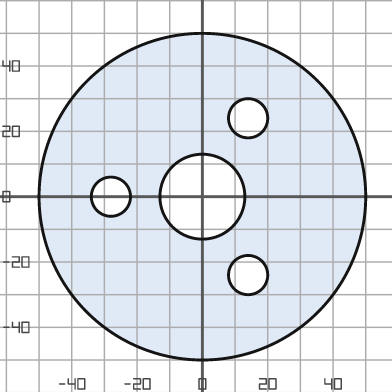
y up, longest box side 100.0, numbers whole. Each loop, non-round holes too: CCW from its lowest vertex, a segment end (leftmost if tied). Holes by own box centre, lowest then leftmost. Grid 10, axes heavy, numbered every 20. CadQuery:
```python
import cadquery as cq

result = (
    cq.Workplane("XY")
    .moveTo(0.0, 0.0)
    .circle(50.0)
    .moveTo(14.0, -24.0)
    .circle(6.0)
    .moveTo(-28.0, 0.0)
    .circle(6.0)
    .moveTo(0.0, 0.0)
    .circle(13.0)
    .moveTo(14.0, 24.0)
    .circle(6.0)
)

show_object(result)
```